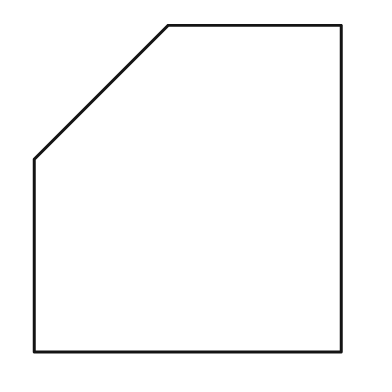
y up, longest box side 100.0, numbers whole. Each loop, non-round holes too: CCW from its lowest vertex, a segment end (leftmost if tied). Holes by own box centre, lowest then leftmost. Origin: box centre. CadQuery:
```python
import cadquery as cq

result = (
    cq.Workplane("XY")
    .moveTo(-47.0, -50.0)
    .lineTo(47.0, -50.0)
    .lineTo(47.0, 50.0)
    .lineTo(-6.0, 50.0)
    .lineTo(-47.0, 9.0)
    .close()
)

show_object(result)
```